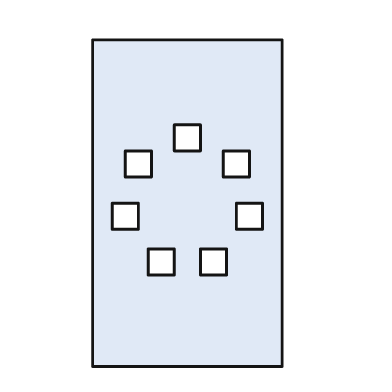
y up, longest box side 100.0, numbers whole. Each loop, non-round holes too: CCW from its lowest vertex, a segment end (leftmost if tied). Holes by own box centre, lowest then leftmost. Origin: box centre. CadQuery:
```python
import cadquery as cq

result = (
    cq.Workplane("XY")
    .moveTo(-29.0, -50.0)
    .lineTo(29.0, -50.0)
    .lineTo(29.0, 50.0)
    .lineTo(-29.0, 50.0)
    .close()
    .moveTo(-12.0, -22.0)
    .lineTo(-4.0, -22.0)
    .lineTo(-4.0, -14.0)
    .lineTo(-12.0, -14.0)
    .close()
    .moveTo(4.0, -22.0)
    .lineTo(12.0, -22.0)
    .lineTo(12.0, -14.0)
    .lineTo(4.0, -14.0)
    .close()
    .moveTo(-23.0, -8.0)
    .lineTo(-15.0, -8.0)
    .lineTo(-15.0, 0.0)
    .lineTo(-23.0, 0.0)
    .close()
    .moveTo(15.0, -8.0)
    .lineTo(23.0, -8.0)
    .lineTo(23.0, 0.0)
    .lineTo(15.0, 0.0)
    .close()
    .moveTo(-19.0, 8.0)
    .lineTo(-11.0, 8.0)
    .lineTo(-11.0, 16.0)
    .lineTo(-19.0, 16.0)
    .close()
    .moveTo(11.0, 8.0)
    .lineTo(19.0, 8.0)
    .lineTo(19.0, 16.0)
    .lineTo(11.0, 16.0)
    .close()
    .moveTo(-4.0, 16.0)
    .lineTo(4.0, 16.0)
    .lineTo(4.0, 24.0)
    .lineTo(-4.0, 24.0)
    .close()
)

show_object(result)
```